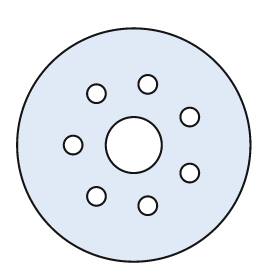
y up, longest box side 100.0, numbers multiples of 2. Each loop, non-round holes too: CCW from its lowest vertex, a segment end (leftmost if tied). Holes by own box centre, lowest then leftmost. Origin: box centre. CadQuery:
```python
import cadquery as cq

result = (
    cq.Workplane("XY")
    .moveTo(0.0, 0.0)
    .circle(50.0)
    .moveTo(6.0, -26.0)
    .circle(4.0)
    .moveTo(-16.0, -22.0)
    .circle(4.0)
    .moveTo(24.0, -12.0)
    .circle(4.0)
    .moveTo(-26.0, 0.0)
    .circle(4.0)
    .moveTo(0.0, 0.0)
    .circle(12.0)
    .moveTo(24.0, 12.0)
    .circle(4.0)
    .moveTo(-16.0, 22.0)
    .circle(4.0)
    .moveTo(6.0, 26.0)
    .circle(4.0)
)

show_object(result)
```